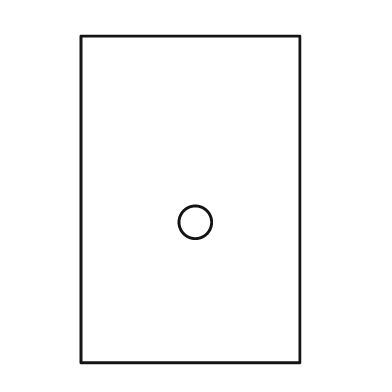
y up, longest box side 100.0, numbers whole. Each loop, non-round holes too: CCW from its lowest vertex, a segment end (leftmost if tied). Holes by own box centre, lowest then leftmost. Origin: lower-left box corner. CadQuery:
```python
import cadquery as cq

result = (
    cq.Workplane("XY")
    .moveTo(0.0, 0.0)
    .lineTo(67.0, 0.0)
    .lineTo(67.0, 100.0)
    .lineTo(0.0, 100.0)
    .close()
    .moveTo(35.0, 43.0)
    .circle(5.0)
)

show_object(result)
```